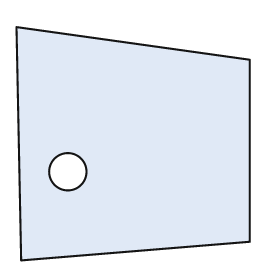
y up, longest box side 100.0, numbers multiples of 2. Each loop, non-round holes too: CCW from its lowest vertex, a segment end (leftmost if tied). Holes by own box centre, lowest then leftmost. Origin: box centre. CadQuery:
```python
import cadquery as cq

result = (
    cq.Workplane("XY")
    .moveTo(-48.0, -50.0)
    .lineTo(50.0, -42.0)
    .lineTo(50.0, 36.0)
    .lineTo(-50.0, 50.0)
    .close()
    .moveTo(-28.0, -12.0)
    .circle(8.0)
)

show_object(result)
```